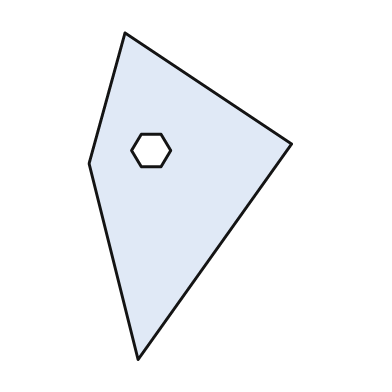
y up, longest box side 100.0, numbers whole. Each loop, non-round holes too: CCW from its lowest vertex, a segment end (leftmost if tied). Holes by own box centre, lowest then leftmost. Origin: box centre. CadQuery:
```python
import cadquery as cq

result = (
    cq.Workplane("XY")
    .moveTo(-16.0, -50.0)
    .lineTo(31.0, 16.0)
    .lineTo(-20.0, 50.0)
    .lineTo(-31.0, 10.0)
    .close()
    .moveTo(-15.0, 9.0)
    .lineTo(-9.0, 9.0)
    .lineTo(-6.0, 14.0)
    .lineTo(-9.0, 19.0)
    .lineTo(-15.0, 19.0)
    .lineTo(-18.0, 14.0)
    .close()
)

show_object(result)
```